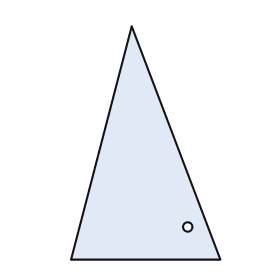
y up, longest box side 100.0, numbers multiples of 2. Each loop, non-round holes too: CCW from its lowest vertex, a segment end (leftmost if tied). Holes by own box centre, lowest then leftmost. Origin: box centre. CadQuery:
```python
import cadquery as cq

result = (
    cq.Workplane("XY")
    .moveTo(-32.0, -50.0)
    .lineTo(32.0, -50.0)
    .lineTo(-6.0, 50.0)
    .close()
    .moveTo(18.0, -36.0)
    .circle(2.0)
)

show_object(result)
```